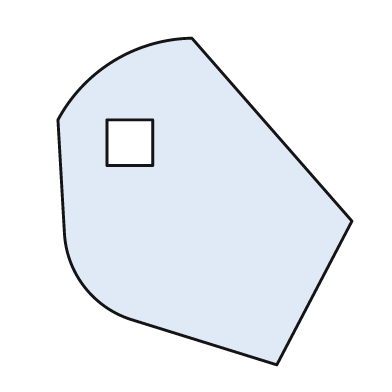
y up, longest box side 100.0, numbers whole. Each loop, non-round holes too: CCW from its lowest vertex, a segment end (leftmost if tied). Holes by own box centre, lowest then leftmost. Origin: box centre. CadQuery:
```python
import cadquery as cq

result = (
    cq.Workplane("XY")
    .moveTo(22.0, -50.0)
    .lineTo(45.0, -6.0)
    .lineTo(-4.0, 50.0)
    .threePointArc((-28.0, 43.0), (-45.0, 25.0))
    .lineTo(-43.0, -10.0)
    .threePointArc((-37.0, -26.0), (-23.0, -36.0))
    .close()
    .moveTo(-30.0, 11.0)
    .lineTo(-16.0, 11.0)
    .lineTo(-16.0, 25.0)
    .lineTo(-30.0, 25.0)
    .close()
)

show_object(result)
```